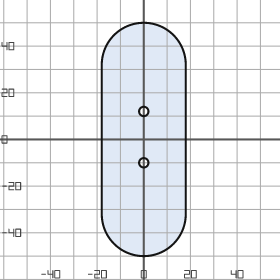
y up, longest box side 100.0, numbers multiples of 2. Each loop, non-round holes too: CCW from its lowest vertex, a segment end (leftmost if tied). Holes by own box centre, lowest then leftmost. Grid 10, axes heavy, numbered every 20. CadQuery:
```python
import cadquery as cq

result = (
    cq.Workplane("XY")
    .moveTo(-18.0, -32.0)
    .threePointArc((0.0, -50.0), (18.0, -32.0))
    .lineTo(18.0, 32.0)
    .threePointArc((0.0, 50.0), (-18.0, 32.0))
    .close()
    .moveTo(0.0, -10.0)
    .circle(2.0)
    .moveTo(0.0, 12.0)
    .circle(2.0)
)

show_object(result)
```